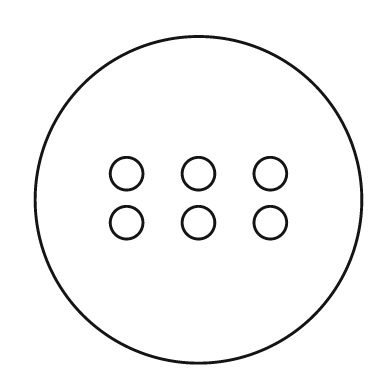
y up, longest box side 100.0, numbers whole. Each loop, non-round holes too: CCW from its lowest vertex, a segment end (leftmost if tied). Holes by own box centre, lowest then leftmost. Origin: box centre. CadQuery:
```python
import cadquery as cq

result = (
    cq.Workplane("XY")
    .moveTo(0.0, 0.0)
    .circle(50.0)
    .moveTo(-22.0, -7.0)
    .circle(5.0)
    .moveTo(0.0, -7.0)
    .circle(5.0)
    .moveTo(22.0, -7.0)
    .circle(5.0)
    .moveTo(-22.0, 8.0)
    .circle(5.0)
    .moveTo(0.0, 8.0)
    .circle(5.0)
    .moveTo(22.0, 8.0)
    .circle(5.0)
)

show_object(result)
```